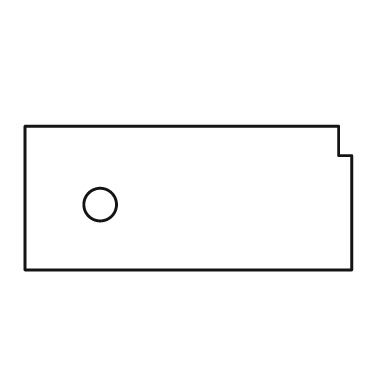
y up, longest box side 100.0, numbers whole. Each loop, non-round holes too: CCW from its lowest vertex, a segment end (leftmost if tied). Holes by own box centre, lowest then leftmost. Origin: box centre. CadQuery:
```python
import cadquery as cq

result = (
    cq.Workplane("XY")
    .moveTo(-50.0, -22.0)
    .lineTo(50.0, -22.0)
    .lineTo(50.0, 13.0)
    .lineTo(46.0, 13.0)
    .lineTo(46.0, 22.0)
    .lineTo(-50.0, 22.0)
    .close()
    .moveTo(-27.0, -2.0)
    .circle(5.0)
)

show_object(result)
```